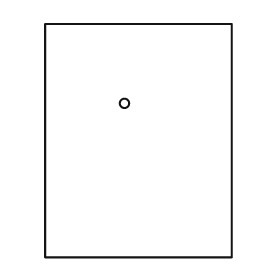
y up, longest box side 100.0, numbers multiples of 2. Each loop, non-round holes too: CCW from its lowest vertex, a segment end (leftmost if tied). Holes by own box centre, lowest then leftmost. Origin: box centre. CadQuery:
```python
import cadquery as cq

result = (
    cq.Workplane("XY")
    .moveTo(-40.0, -50.0)
    .lineTo(40.0, -50.0)
    .lineTo(40.0, 50.0)
    .lineTo(-40.0, 50.0)
    .close()
    .moveTo(-6.0, 16.0)
    .circle(2.0)
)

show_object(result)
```